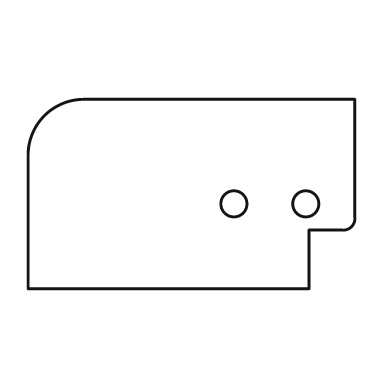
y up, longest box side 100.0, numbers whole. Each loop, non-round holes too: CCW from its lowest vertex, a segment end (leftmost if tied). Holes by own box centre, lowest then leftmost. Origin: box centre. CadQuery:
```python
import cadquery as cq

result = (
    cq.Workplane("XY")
    .moveTo(-50.0, -29.0)
    .lineTo(36.0, -29.0)
    .lineTo(36.0, -11.0)
    .lineTo(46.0, -11.0)
    .threePointArc((49.0, -10.0), (50.0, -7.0))
    .lineTo(50.0, 29.0)
    .lineTo(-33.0, 29.0)
    .threePointArc((-45.0, 24.0), (-50.0, 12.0))
    .close()
    .moveTo(13.0, -3.0)
    .circle(4.0)
    .moveTo(35.0, -3.0)
    .circle(4.0)
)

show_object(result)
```